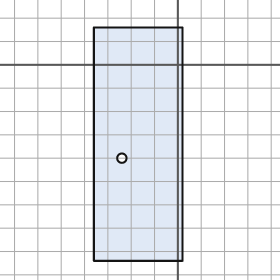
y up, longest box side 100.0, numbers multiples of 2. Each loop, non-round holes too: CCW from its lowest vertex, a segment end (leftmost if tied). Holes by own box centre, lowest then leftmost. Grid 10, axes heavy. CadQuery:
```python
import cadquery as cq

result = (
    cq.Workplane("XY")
    .moveTo(-36.0, -84.0)
    .lineTo(2.0, -84.0)
    .lineTo(2.0, 16.0)
    .lineTo(-36.0, 16.0)
    .close()
    .moveTo(-24.0, -40.0)
    .circle(2.0)
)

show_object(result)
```